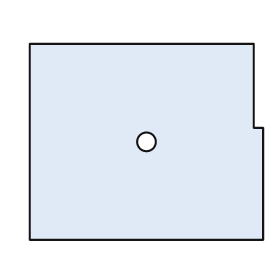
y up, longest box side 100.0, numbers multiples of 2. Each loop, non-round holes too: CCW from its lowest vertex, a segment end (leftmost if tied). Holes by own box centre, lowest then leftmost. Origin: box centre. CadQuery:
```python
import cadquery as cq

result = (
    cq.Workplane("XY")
    .moveTo(-50.0, -42.0)
    .lineTo(50.0, -42.0)
    .lineTo(50.0, 6.0)
    .lineTo(46.0, 6.0)
    .lineTo(46.0, 42.0)
    .lineTo(-50.0, 42.0)
    .close()
    .moveTo(0.0, 0.0)
    .circle(4.0)
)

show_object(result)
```